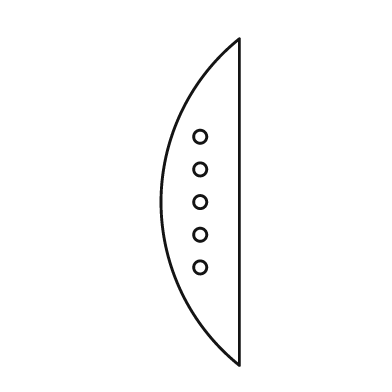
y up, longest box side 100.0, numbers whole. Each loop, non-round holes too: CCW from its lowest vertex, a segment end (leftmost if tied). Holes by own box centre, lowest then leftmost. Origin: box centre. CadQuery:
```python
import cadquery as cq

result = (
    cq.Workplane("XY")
    .moveTo(12.0, -50.0)
    .lineTo(12.0, 50.0)
    .threePointArc((-12.0, 0.0), (12.0, -50.0))
    .close()
    .moveTo(0.0, -20.0)
    .circle(2.0)
    .moveTo(0.0, -10.0)
    .circle(2.0)
    .moveTo(0.0, 0.0)
    .circle(2.0)
    .moveTo(0.0, 10.0)
    .circle(2.0)
    .moveTo(0.0, 20.0)
    .circle(2.0)
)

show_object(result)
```